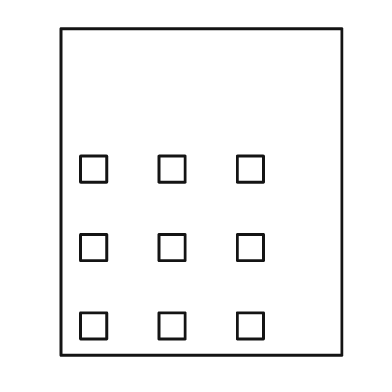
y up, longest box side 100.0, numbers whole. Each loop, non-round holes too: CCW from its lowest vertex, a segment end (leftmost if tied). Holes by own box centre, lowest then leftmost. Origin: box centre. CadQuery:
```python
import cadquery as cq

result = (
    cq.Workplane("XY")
    .moveTo(-43.0, -50.0)
    .lineTo(43.0, -50.0)
    .lineTo(43.0, 50.0)
    .lineTo(-43.0, 50.0)
    .close()
    .moveTo(-37.0, -45.0)
    .lineTo(-29.0, -45.0)
    .lineTo(-29.0, -37.0)
    .lineTo(-37.0, -37.0)
    .close()
    .moveTo(-13.0, -45.0)
    .lineTo(-5.0, -45.0)
    .lineTo(-5.0, -37.0)
    .lineTo(-13.0, -37.0)
    .close()
    .moveTo(11.0, -45.0)
    .lineTo(19.0, -45.0)
    .lineTo(19.0, -37.0)
    .lineTo(11.0, -37.0)
    .close()
    .moveTo(-37.0, -21.0)
    .lineTo(-29.0, -21.0)
    .lineTo(-29.0, -13.0)
    .lineTo(-37.0, -13.0)
    .close()
    .moveTo(-13.0, -21.0)
    .lineTo(-5.0, -21.0)
    .lineTo(-5.0, -13.0)
    .lineTo(-13.0, -13.0)
    .close()
    .moveTo(11.0, -21.0)
    .lineTo(19.0, -21.0)
    .lineTo(19.0, -13.0)
    .lineTo(11.0, -13.0)
    .close()
    .moveTo(-37.0, 3.0)
    .lineTo(-29.0, 3.0)
    .lineTo(-29.0, 11.0)
    .lineTo(-37.0, 11.0)
    .close()
    .moveTo(-13.0, 3.0)
    .lineTo(-5.0, 3.0)
    .lineTo(-5.0, 11.0)
    .lineTo(-13.0, 11.0)
    .close()
    .moveTo(11.0, 3.0)
    .lineTo(19.0, 3.0)
    .lineTo(19.0, 11.0)
    .lineTo(11.0, 11.0)
    .close()
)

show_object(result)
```